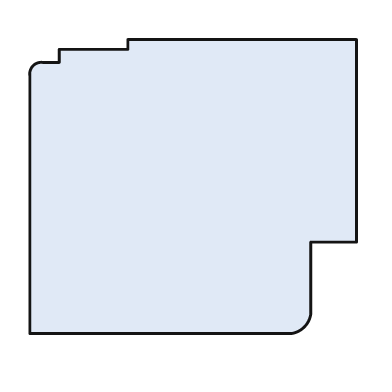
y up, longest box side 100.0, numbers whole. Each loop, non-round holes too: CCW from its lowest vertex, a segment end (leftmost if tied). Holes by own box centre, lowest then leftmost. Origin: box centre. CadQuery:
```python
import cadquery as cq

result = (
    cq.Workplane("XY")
    .moveTo(-50.0, -45.0)
    .lineTo(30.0, -45.0)
    .threePointArc((34.0, -43.0), (36.0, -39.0))
    .lineTo(36.0, -17.0)
    .lineTo(50.0, -17.0)
    .lineTo(50.0, 45.0)
    .lineTo(-20.0, 45.0)
    .lineTo(-20.0, 42.0)
    .lineTo(-41.0, 42.0)
    .lineTo(-41.0, 38.0)
    .lineTo(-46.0, 38.0)
    .threePointArc((-49.0, 37.0), (-50.0, 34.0))
    .close()
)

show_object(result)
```